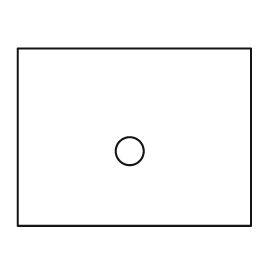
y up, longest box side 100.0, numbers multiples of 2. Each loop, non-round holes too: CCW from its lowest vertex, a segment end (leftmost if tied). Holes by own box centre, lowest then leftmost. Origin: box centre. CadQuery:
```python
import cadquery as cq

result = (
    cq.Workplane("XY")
    .moveTo(-50.0, -38.0)
    .lineTo(50.0, -38.0)
    .lineTo(50.0, 38.0)
    .lineTo(-50.0, 38.0)
    .close()
    .moveTo(-2.0, -6.0)
    .circle(6.0)
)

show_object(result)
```